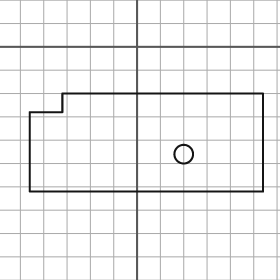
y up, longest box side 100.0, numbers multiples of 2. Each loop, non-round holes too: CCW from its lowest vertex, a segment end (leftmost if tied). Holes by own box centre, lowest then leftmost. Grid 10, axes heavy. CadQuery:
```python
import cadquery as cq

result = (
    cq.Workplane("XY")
    .moveTo(-46.0, -62.0)
    .lineTo(54.0, -62.0)
    .lineTo(54.0, -20.0)
    .lineTo(-32.0, -20.0)
    .lineTo(-32.0, -28.0)
    .lineTo(-46.0, -28.0)
    .close()
    .moveTo(20.0, -46.0)
    .circle(4.0)
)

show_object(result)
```